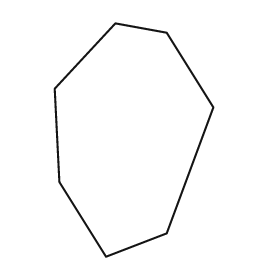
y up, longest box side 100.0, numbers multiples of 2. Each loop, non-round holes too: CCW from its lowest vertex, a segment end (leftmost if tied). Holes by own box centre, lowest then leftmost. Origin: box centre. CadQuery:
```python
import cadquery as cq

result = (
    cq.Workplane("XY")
    .moveTo(-12.0, -50.0)
    .lineTo(14.0, -40.0)
    .lineTo(34.0, 14.0)
    .lineTo(14.0, 46.0)
    .lineTo(-8.0, 50.0)
    .lineTo(-34.0, 22.0)
    .lineTo(-32.0, -18.0)
    .close()
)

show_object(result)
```